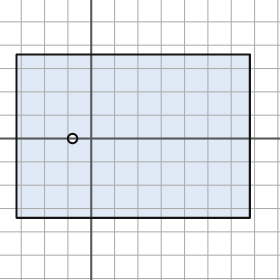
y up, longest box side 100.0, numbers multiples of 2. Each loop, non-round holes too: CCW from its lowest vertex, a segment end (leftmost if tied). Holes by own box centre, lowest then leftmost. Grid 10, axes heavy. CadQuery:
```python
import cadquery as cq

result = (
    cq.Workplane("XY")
    .moveTo(-32.0, -34.0)
    .lineTo(68.0, -34.0)
    .lineTo(68.0, 36.0)
    .lineTo(-32.0, 36.0)
    .close()
    .moveTo(-8.0, 0.0)
    .circle(2.0)
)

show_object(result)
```